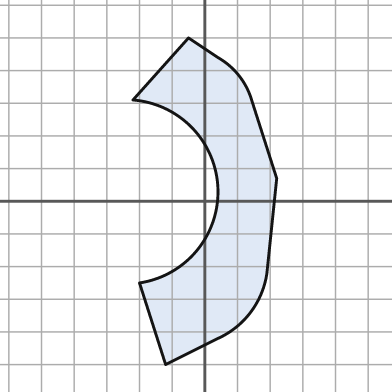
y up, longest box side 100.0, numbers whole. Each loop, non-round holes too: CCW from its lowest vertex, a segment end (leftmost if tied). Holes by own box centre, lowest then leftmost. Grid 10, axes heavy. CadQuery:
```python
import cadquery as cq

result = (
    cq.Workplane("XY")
    .moveTo(-12.0, -50.0)
    .lineTo(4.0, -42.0)
    .threePointArc((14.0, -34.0), (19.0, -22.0))
    .lineTo(22.0, 7.0)
    .lineTo(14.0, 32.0)
    .threePointArc((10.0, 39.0), (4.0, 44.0))
    .lineTo(-5.0, 50.0)
    .lineTo(-22.0, 31.0)
    .threePointArc((4.0, 4.0), (-20.0, -25.0))
    .close()
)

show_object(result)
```